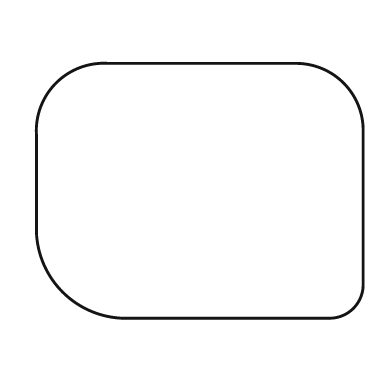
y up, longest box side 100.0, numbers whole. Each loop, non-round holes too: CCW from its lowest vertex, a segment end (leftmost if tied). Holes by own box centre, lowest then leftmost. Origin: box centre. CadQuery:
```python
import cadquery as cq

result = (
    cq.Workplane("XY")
    .moveTo(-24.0, -39.0)
    .lineTo(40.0, -39.0)
    .threePointArc((47.0, -36.0), (50.0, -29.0))
    .lineTo(50.0, 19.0)
    .threePointArc((44.0, 33.0), (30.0, 39.0))
    .lineTo(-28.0, 39.0)
    .threePointArc((-44.0, 33.0), (-50.0, 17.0))
    .lineTo(-50.0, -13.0)
    .threePointArc((-42.0, -31.0), (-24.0, -39.0))
    .close()
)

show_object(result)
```